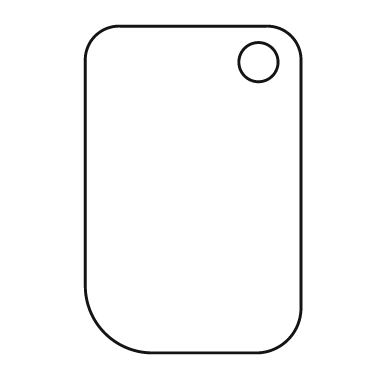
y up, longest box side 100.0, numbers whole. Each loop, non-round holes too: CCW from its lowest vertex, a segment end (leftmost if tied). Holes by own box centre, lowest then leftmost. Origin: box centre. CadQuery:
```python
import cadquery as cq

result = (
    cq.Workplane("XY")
    .moveTo(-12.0, -50.0)
    .lineTo(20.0, -50.0)
    .threePointArc((29.0, -46.0), (33.0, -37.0))
    .lineTo(33.0, 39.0)
    .threePointArc((30.0, 47.0), (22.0, 50.0))
    .lineTo(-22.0, 50.0)
    .threePointArc((-30.0, 47.0), (-33.0, 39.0))
    .lineTo(-33.0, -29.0)
    .threePointArc((-27.0, -44.0), (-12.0, -50.0))
    .close()
    .moveTo(20.0, 39.0)
    .circle(6.0)
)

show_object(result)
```